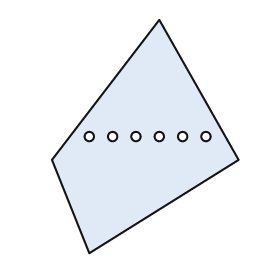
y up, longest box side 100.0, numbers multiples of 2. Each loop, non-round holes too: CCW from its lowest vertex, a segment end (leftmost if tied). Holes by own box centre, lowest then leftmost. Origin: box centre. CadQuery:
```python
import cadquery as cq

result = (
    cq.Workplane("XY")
    .moveTo(-24.0, -50.0)
    .lineTo(40.0, -10.0)
    .lineTo(6.0, 50.0)
    .lineTo(-40.0, -10.0)
    .close()
    .moveTo(-24.0, 0.0)
    .circle(2.0)
    .moveTo(-14.0, 0.0)
    .circle(2.0)
    .moveTo(-4.0, 0.0)
    .circle(2.0)
    .moveTo(6.0, 0.0)
    .circle(2.0)
    .moveTo(16.0, 0.0)
    .circle(2.0)
    .moveTo(26.0, 0.0)
    .circle(2.0)
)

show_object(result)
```